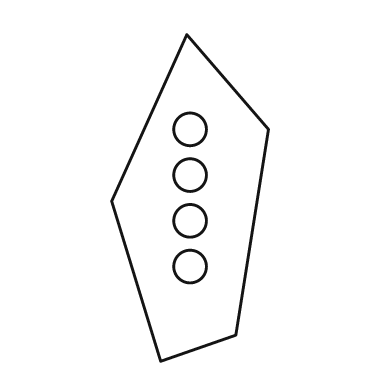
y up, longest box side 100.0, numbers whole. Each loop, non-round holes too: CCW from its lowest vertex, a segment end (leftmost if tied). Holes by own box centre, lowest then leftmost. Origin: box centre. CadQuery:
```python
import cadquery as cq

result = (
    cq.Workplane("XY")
    .moveTo(-9.0, -50.0)
    .lineTo(14.0, -42.0)
    .lineTo(24.0, 21.0)
    .lineTo(-1.0, 50.0)
    .lineTo(-24.0, -1.0)
    .close()
    .moveTo(0.0, -21.0)
    .circle(5.0)
    .moveTo(0.0, -7.0)
    .circle(5.0)
    .moveTo(0.0, 7.0)
    .circle(5.0)
    .moveTo(0.0, 21.0)
    .circle(5.0)
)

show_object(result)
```